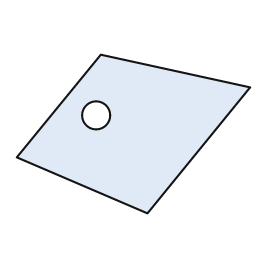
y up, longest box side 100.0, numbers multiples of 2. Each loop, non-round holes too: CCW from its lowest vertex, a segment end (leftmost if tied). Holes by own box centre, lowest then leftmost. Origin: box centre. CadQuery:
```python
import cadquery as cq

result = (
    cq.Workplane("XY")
    .moveTo(6.0, -34.0)
    .lineTo(50.0, 20.0)
    .lineTo(-14.0, 34.0)
    .lineTo(-50.0, -10.0)
    .close()
    .moveTo(-16.0, 8.0)
    .circle(6.0)
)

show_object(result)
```